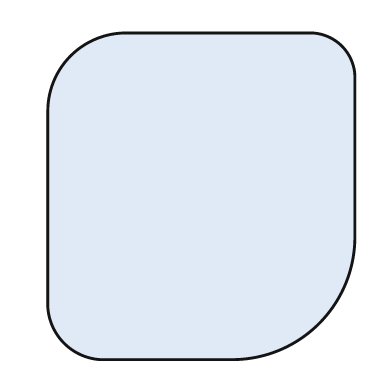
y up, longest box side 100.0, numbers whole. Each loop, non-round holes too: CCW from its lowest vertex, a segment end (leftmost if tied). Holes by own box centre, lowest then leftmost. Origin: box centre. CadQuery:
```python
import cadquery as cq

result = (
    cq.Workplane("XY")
    .moveTo(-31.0, -50.0)
    .lineTo(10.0, -50.0)
    .threePointArc((36.0, -39.0), (47.0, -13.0))
    .lineTo(47.0, 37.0)
    .threePointArc((43.0, 46.0), (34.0, 50.0))
    .lineTo(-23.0, 50.0)
    .threePointArc((-40.0, 43.0), (-47.0, 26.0))
    .lineTo(-47.0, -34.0)
    .threePointArc((-42.0, -45.0), (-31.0, -50.0))
    .close()
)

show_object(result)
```